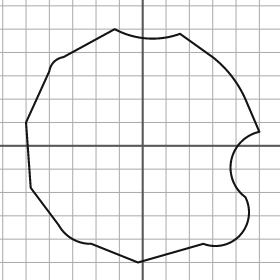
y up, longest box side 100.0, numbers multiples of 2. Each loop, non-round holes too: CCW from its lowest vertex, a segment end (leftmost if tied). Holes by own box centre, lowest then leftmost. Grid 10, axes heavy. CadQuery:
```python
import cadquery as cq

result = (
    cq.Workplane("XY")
    .moveTo(-2.0, -50.0)
    .lineTo(26.0, -42.0)
    .threePointArc((42.0, -38.0), (44.0, -22.0))
    .threePointArc((38.0, -6.0), (50.0, 6.0))
    .lineTo(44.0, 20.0)
    .threePointArc((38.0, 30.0), (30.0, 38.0))
    .lineTo(16.0, 48.0)
    .threePointArc((2.0, 46.0), (-12.0, 50.0))
    .lineTo(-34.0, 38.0)
    .threePointArc((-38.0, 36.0), (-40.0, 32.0))
    .lineTo(-50.0, 10.0)
    .lineTo(-48.0, -18.0)
    .lineTo(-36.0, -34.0)
    .threePointArc((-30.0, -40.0), (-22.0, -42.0))
    .close()
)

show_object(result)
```